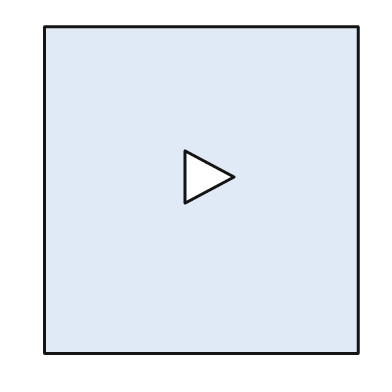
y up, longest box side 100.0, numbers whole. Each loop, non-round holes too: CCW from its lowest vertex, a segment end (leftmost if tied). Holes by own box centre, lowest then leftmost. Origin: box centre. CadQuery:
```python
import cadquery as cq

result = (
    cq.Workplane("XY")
    .moveTo(-48.0, -50.0)
    .lineTo(48.0, -50.0)
    .lineTo(48.0, 50.0)
    .lineTo(-48.0, 50.0)
    .close()
    .moveTo(-5.0, -4.0)
    .lineTo(10.0, 4.0)
    .lineTo(-5.0, 12.0)
    .close()
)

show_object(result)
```